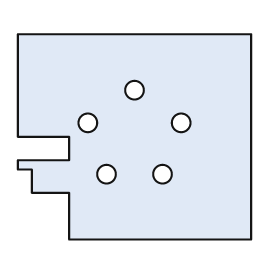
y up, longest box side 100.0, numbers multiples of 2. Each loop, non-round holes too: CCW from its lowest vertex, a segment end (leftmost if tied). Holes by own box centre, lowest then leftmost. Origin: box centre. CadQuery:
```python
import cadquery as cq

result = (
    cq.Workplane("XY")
    .moveTo(-28.0, -44.0)
    .lineTo(50.0, -44.0)
    .lineTo(50.0, 44.0)
    .lineTo(-50.0, 44.0)
    .lineTo(-50.0, 0.0)
    .lineTo(-28.0, 0.0)
    .lineTo(-28.0, -10.0)
    .lineTo(-50.0, -10.0)
    .lineTo(-50.0, -14.0)
    .lineTo(-44.0, -14.0)
    .lineTo(-44.0, -24.0)
    .lineTo(-28.0, -24.0)
    .close()
    .moveTo(-12.0, -16.0)
    .circle(4.0)
    .moveTo(12.0, -16.0)
    .circle(4.0)
    .moveTo(-20.0, 6.0)
    .circle(4.0)
    .moveTo(20.0, 6.0)
    .circle(4.0)
    .moveTo(0.0, 20.0)
    .circle(4.0)
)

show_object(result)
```